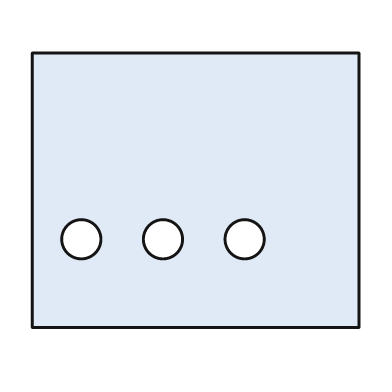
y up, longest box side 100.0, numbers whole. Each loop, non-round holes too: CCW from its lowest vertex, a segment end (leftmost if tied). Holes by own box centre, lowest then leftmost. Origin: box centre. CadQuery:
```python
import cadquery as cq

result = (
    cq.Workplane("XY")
    .moveTo(-50.0, -42.0)
    .lineTo(50.0, -42.0)
    .lineTo(50.0, 42.0)
    .lineTo(-50.0, 42.0)
    .close()
    .moveTo(-35.0, -15.0)
    .circle(6.0)
    .moveTo(-10.0, -15.0)
    .circle(6.0)
    .moveTo(15.0, -15.0)
    .circle(6.0)
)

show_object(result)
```